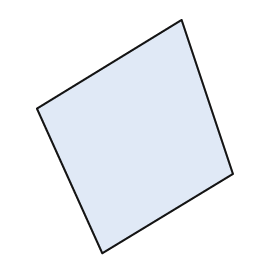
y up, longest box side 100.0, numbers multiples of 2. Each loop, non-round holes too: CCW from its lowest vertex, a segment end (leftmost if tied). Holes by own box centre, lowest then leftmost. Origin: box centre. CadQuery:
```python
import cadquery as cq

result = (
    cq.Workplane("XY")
    .moveTo(-14.0, -50.0)
    .lineTo(42.0, -16.0)
    .lineTo(20.0, 50.0)
    .lineTo(-42.0, 12.0)
    .close()
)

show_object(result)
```